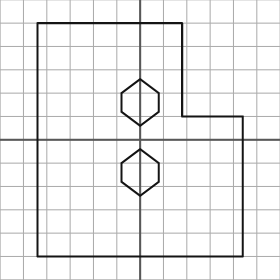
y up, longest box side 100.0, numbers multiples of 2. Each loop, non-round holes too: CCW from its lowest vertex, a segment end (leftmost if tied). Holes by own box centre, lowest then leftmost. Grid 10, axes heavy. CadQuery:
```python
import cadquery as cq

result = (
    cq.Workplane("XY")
    .moveTo(-44.0, -50.0)
    .lineTo(44.0, -50.0)
    .lineTo(44.0, 10.0)
    .lineTo(18.0, 10.0)
    .lineTo(18.0, 50.0)
    .lineTo(-44.0, 50.0)
    .close()
    .moveTo(0.0, -24.0)
    .lineTo(8.0, -18.0)
    .lineTo(8.0, -10.0)
    .lineTo(0.0, -4.0)
    .lineTo(-8.0, -10.0)
    .lineTo(-8.0, -18.0)
    .close()
    .moveTo(0.0, 6.0)
    .lineTo(8.0, 12.0)
    .lineTo(8.0, 20.0)
    .lineTo(0.0, 26.0)
    .lineTo(-8.0, 20.0)
    .lineTo(-8.0, 12.0)
    .close()
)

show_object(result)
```